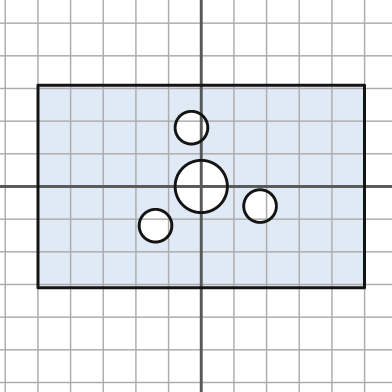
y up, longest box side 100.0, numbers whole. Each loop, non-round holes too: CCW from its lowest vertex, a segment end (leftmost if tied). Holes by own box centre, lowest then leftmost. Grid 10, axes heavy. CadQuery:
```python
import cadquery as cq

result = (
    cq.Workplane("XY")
    .moveTo(-50.0, -31.0)
    .lineTo(50.0, -31.0)
    .lineTo(50.0, 31.0)
    .lineTo(-50.0, 31.0)
    .close()
    .moveTo(-14.0, -12.0)
    .circle(5.0)
    .moveTo(18.0, -6.0)
    .circle(5.0)
    .moveTo(0.0, 0.0)
    .circle(8.0)
    .moveTo(-3.0, 18.0)
    .circle(5.0)
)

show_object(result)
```